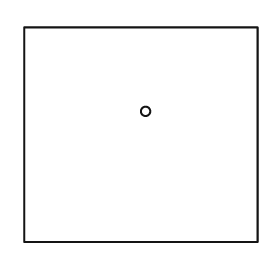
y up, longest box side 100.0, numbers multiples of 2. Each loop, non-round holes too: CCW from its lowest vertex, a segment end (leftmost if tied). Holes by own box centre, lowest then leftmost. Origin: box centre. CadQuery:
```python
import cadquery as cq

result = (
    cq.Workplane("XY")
    .moveTo(-50.0, -46.0)
    .lineTo(50.0, -46.0)
    .lineTo(50.0, 46.0)
    .lineTo(-50.0, 46.0)
    .close()
    .moveTo(2.0, 10.0)
    .circle(2.0)
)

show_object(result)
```